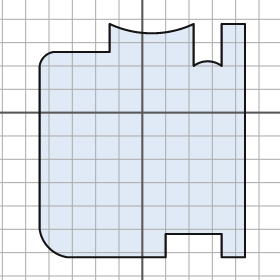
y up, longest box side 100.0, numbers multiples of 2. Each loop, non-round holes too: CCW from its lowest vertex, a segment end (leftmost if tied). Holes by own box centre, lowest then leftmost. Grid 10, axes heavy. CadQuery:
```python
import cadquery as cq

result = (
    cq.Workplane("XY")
    .moveTo(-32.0, -62.0)
    .lineTo(10.0, -62.0)
    .lineTo(10.0, -52.0)
    .lineTo(34.0, -52.0)
    .lineTo(34.0, -62.0)
    .lineTo(44.0, -62.0)
    .lineTo(44.0, 38.0)
    .lineTo(34.0, 38.0)
    .lineTo(34.0, 20.0)
    .threePointArc((28.0, 22.0), (22.0, 20.0))
    .lineTo(22.0, 38.0)
    .threePointArc((4.0, 34.0), (-14.0, 38.0))
    .lineTo(-14.0, 26.0)
    .lineTo(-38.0, 26.0)
    .threePointArc((-42.0, 24.0), (-44.0, 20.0))
    .lineTo(-44.0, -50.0)
    .threePointArc((-40.0, -58.0), (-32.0, -62.0))
    .close()
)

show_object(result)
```